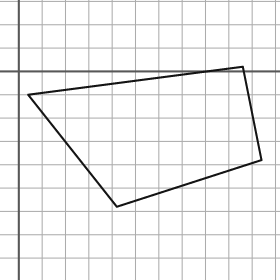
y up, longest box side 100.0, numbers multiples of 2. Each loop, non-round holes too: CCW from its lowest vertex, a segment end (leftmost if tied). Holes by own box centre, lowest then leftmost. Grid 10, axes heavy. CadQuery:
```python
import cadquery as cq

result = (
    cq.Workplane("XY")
    .moveTo(42.0, -58.0)
    .lineTo(104.0, -38.0)
    .lineTo(96.0, 2.0)
    .lineTo(4.0, -10.0)
    .close()
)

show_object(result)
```